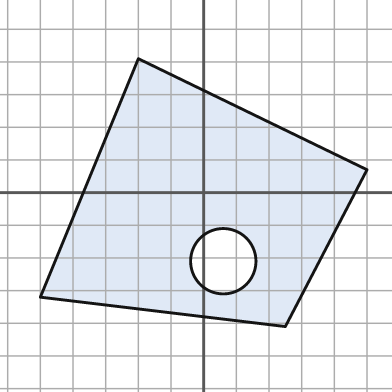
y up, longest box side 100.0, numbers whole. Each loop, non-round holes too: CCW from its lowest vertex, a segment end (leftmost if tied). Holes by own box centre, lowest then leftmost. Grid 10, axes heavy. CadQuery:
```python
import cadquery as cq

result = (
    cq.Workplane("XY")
    .moveTo(25.0, -41.0)
    .lineTo(50.0, 7.0)
    .lineTo(-20.0, 41.0)
    .lineTo(-50.0, -32.0)
    .close()
    .moveTo(6.0, -21.0)
    .circle(10.0)
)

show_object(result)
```